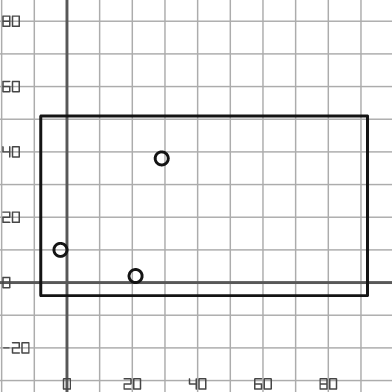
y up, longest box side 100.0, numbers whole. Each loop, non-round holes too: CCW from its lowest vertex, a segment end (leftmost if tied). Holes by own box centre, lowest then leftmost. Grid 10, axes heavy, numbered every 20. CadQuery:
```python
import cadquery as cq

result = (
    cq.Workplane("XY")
    .moveTo(-8.0, -4.0)
    .lineTo(92.0, -4.0)
    .lineTo(92.0, 51.0)
    .lineTo(-8.0, 51.0)
    .close()
    .moveTo(21.0, 2.0)
    .circle(2.0)
    .moveTo(-2.0, 10.0)
    .circle(2.0)
    .moveTo(29.0, 38.0)
    .circle(2.0)
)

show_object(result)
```